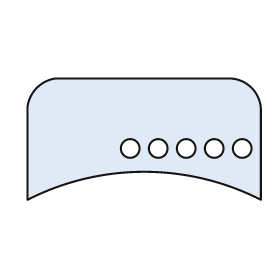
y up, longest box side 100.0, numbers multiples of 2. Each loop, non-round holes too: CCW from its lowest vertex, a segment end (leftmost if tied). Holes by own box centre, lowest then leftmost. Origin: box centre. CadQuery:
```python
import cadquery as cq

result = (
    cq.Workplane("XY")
    .moveTo(-50.0, -26.0)
    .threePointArc((0.0, -14.0), (50.0, -26.0))
    .lineTo(50.0, 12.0)
    .threePointArc((46.0, 22.0), (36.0, 26.0))
    .lineTo(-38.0, 26.0)
    .threePointArc((-46.0, 22.0), (-50.0, 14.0))
    .close()
    .moveTo(-6.0, -4.0)
    .circle(4.0)
    .moveTo(6.0, -4.0)
    .circle(4.0)
    .moveTo(18.0, -4.0)
    .circle(4.0)
    .moveTo(30.0, -4.0)
    .circle(4.0)
    .moveTo(42.0, -4.0)
    .circle(4.0)
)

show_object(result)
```